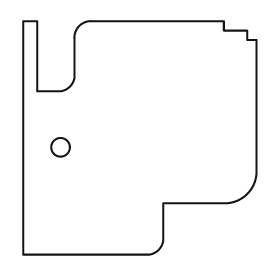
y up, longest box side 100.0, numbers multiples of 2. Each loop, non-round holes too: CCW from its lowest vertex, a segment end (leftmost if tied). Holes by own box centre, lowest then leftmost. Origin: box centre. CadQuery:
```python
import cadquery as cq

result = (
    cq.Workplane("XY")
    .moveTo(-50.0, -50.0)
    .lineTo(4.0, -50.0)
    .threePointArc((8.0, -48.0), (10.0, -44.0))
    .lineTo(10.0, -28.0)
    .lineTo(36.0, -28.0)
    .threePointArc((46.0, -24.0), (50.0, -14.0))
    .lineTo(50.0, 42.0)
    .lineTo(46.0, 42.0)
    .lineTo(46.0, 46.0)
    .lineTo(36.0, 46.0)
    .lineTo(36.0, 50.0)
    .lineTo(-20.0, 50.0)
    .threePointArc((-26.0, 48.0), (-28.0, 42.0))
    .lineTo(-28.0, 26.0)
    .threePointArc((-30.0, 22.0), (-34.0, 20.0))
    .lineTo(-44.0, 20.0)
    .lineTo(-44.0, 50.0)
    .lineTo(-50.0, 50.0)
    .close()
    .moveTo(-34.0, -4.0)
    .circle(4.0)
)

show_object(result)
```